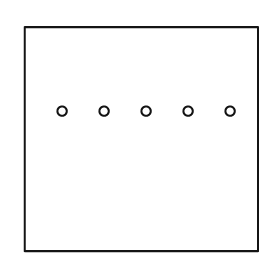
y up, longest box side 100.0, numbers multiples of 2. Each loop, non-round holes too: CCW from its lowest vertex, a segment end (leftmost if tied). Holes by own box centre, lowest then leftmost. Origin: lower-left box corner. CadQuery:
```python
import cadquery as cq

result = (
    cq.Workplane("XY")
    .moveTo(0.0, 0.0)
    .lineTo(100.0, 0.0)
    .lineTo(100.0, 96.0)
    .lineTo(0.0, 96.0)
    .close()
    .moveTo(16.0, 60.0)
    .circle(2.0)
    .moveTo(34.0, 60.0)
    .circle(2.0)
    .moveTo(52.0, 60.0)
    .circle(2.0)
    .moveTo(70.0, 60.0)
    .circle(2.0)
    .moveTo(88.0, 60.0)
    .circle(2.0)
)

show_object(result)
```